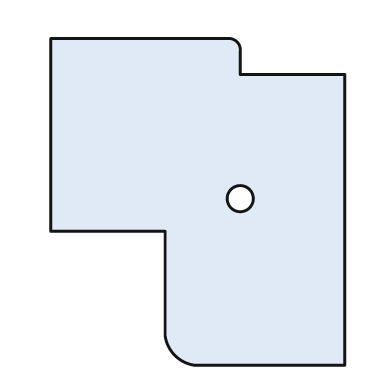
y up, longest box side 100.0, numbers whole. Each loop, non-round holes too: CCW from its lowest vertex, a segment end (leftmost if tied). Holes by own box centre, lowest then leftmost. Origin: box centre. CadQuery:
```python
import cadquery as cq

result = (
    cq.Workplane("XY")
    .moveTo(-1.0, -50.0)
    .lineTo(45.0, -50.0)
    .lineTo(45.0, 39.0)
    .lineTo(13.0, 39.0)
    .lineTo(13.0, 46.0)
    .threePointArc((12.0, 49.0), (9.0, 50.0))
    .lineTo(-45.0, 50.0)
    .lineTo(-45.0, -9.0)
    .lineTo(-10.0, -9.0)
    .lineTo(-10.0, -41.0)
    .threePointArc((-7.0, -47.0), (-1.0, -50.0))
    .close()
    .moveTo(13.0, 1.0)
    .circle(4.0)
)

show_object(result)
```